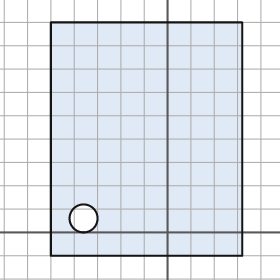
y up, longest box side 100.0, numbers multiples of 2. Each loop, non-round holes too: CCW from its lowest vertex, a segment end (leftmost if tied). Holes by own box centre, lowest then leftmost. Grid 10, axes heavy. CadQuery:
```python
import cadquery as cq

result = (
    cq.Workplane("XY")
    .moveTo(-50.0, -10.0)
    .lineTo(32.0, -10.0)
    .lineTo(32.0, 90.0)
    .lineTo(-50.0, 90.0)
    .close()
    .moveTo(-36.0, 6.0)
    .circle(6.0)
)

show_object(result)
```